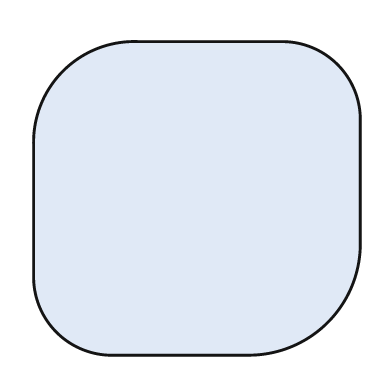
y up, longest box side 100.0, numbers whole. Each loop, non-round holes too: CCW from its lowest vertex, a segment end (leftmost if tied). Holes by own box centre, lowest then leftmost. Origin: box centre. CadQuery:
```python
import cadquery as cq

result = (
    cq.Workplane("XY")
    .moveTo(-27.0, -48.0)
    .lineTo(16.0, -48.0)
    .threePointArc((40.0, -38.0), (50.0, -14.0))
    .lineTo(50.0, 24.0)
    .threePointArc((43.0, 41.0), (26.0, 48.0))
    .lineTo(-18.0, 48.0)
    .threePointArc((-41.0, 39.0), (-50.0, 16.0))
    .lineTo(-50.0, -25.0)
    .threePointArc((-43.0, -41.0), (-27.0, -48.0))
    .close()
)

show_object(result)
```